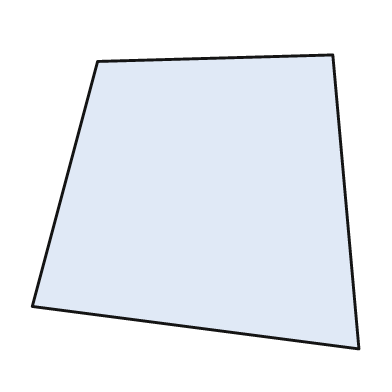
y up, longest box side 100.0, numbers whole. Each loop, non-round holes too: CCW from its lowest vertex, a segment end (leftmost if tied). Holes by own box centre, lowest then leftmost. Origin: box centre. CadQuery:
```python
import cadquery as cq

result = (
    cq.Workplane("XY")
    .moveTo(50.0, -45.0)
    .lineTo(42.0, 45.0)
    .lineTo(-30.0, 43.0)
    .lineTo(-50.0, -32.0)
    .close()
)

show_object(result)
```